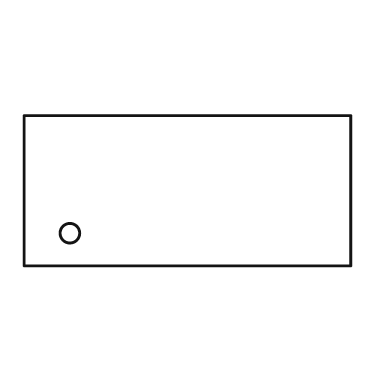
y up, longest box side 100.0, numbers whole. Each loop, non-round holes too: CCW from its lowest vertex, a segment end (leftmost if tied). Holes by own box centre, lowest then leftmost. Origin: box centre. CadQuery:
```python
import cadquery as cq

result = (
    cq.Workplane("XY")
    .moveTo(-50.0, -23.0)
    .lineTo(50.0, -23.0)
    .lineTo(50.0, 23.0)
    .lineTo(-50.0, 23.0)
    .close()
    .moveTo(-36.0, -13.0)
    .circle(3.0)
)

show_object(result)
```